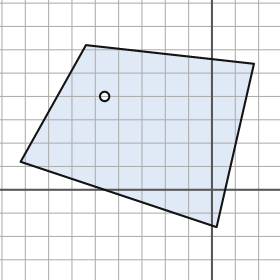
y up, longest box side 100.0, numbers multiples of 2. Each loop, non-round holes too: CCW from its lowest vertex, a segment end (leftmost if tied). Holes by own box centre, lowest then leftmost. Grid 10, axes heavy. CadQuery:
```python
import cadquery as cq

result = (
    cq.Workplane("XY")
    .moveTo(2.0, -16.0)
    .lineTo(18.0, 54.0)
    .lineTo(-54.0, 62.0)
    .lineTo(-82.0, 12.0)
    .close()
    .moveTo(-46.0, 40.0)
    .circle(2.0)
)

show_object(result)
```